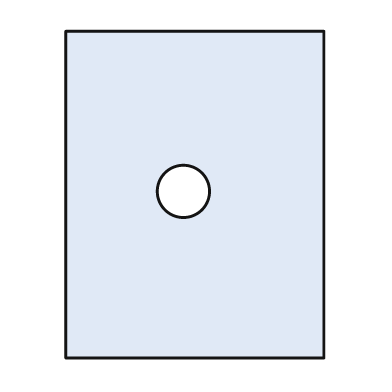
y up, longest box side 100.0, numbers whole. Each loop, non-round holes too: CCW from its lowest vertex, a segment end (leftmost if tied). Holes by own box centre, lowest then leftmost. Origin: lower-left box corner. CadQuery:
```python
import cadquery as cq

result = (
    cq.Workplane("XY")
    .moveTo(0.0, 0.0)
    .lineTo(79.0, 0.0)
    .lineTo(79.0, 100.0)
    .lineTo(0.0, 100.0)
    .close()
    .moveTo(36.0, 51.0)
    .circle(8.0)
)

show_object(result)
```